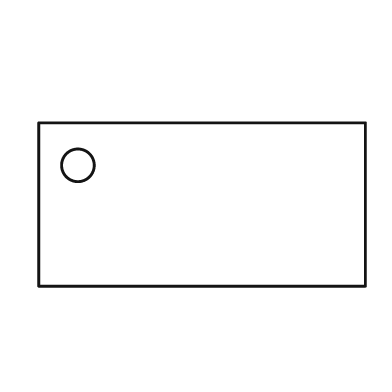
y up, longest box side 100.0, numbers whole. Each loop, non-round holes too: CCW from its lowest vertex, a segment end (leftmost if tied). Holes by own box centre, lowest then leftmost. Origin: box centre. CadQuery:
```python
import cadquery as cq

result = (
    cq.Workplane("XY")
    .moveTo(-50.0, -25.0)
    .lineTo(50.0, -25.0)
    .lineTo(50.0, 25.0)
    .lineTo(-50.0, 25.0)
    .close()
    .moveTo(-38.0, 12.0)
    .circle(5.0)
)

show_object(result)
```